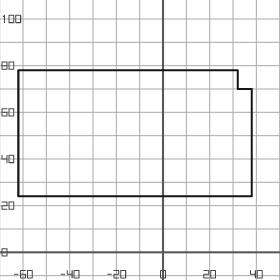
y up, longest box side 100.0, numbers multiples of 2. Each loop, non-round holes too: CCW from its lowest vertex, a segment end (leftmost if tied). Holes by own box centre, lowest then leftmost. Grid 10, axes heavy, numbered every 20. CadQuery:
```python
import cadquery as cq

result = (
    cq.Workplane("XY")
    .moveTo(-62.0, 24.0)
    .lineTo(38.0, 24.0)
    .lineTo(38.0, 70.0)
    .lineTo(32.0, 70.0)
    .lineTo(32.0, 78.0)
    .lineTo(-62.0, 78.0)
    .close()
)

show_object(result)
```